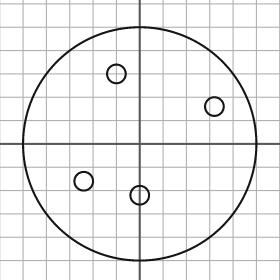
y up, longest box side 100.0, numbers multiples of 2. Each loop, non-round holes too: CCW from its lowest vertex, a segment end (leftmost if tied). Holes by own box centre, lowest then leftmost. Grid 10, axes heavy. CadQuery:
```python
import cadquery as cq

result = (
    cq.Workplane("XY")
    .moveTo(0.0, 0.0)
    .circle(50.0)
    .moveTo(0.0, -22.0)
    .circle(4.0)
    .moveTo(-24.0, -16.0)
    .circle(4.0)
    .moveTo(32.0, 16.0)
    .circle(4.0)
    .moveTo(-10.0, 30.0)
    .circle(4.0)
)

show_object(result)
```